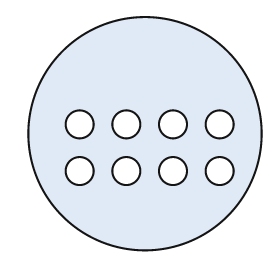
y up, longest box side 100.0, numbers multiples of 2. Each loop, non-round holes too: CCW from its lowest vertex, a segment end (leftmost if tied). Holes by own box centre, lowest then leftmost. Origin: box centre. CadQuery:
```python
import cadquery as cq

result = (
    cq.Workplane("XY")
    .moveTo(0.0, 0.0)
    .circle(50.0)
    .moveTo(-28.0, -16.0)
    .circle(6.0)
    .moveTo(-8.0, -16.0)
    .circle(6.0)
    .moveTo(12.0, -16.0)
    .circle(6.0)
    .moveTo(32.0, -16.0)
    .circle(6.0)
    .moveTo(-28.0, 4.0)
    .circle(6.0)
    .moveTo(-8.0, 4.0)
    .circle(6.0)
    .moveTo(12.0, 4.0)
    .circle(6.0)
    .moveTo(32.0, 4.0)
    .circle(6.0)
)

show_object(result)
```